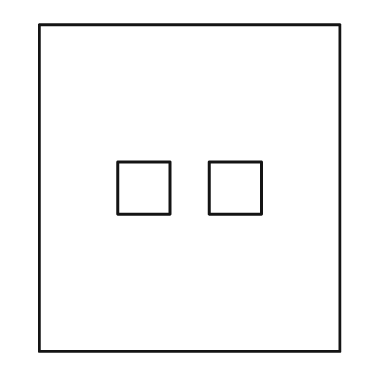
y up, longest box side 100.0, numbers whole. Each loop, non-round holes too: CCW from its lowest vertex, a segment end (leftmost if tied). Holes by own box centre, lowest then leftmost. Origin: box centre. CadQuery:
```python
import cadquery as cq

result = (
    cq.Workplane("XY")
    .moveTo(-46.0, -50.0)
    .lineTo(46.0, -50.0)
    .lineTo(46.0, 50.0)
    .lineTo(-46.0, 50.0)
    .close()
    .moveTo(-22.0, -8.0)
    .lineTo(-6.0, -8.0)
    .lineTo(-6.0, 8.0)
    .lineTo(-22.0, 8.0)
    .close()
    .moveTo(6.0, -8.0)
    .lineTo(22.0, -8.0)
    .lineTo(22.0, 8.0)
    .lineTo(6.0, 8.0)
    .close()
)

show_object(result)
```